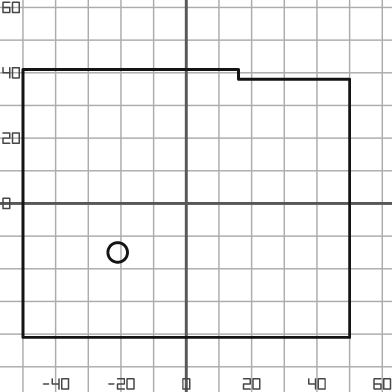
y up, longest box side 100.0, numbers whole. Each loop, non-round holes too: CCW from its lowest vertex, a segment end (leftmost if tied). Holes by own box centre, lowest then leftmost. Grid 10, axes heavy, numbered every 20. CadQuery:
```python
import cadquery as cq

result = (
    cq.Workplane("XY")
    .moveTo(-50.0, -41.0)
    .lineTo(50.0, -41.0)
    .lineTo(50.0, 38.0)
    .lineTo(16.0, 38.0)
    .lineTo(16.0, 41.0)
    .lineTo(-50.0, 41.0)
    .close()
    .moveTo(-21.0, -15.0)
    .circle(3.0)
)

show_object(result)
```